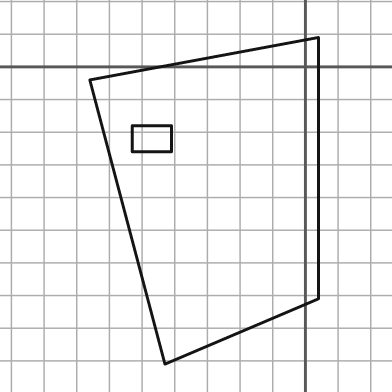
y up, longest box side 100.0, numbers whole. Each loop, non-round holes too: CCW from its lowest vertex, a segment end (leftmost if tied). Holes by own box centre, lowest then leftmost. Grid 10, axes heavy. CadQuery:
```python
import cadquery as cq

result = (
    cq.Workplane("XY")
    .moveTo(-43.0, -91.0)
    .lineTo(4.0, -71.0)
    .lineTo(4.0, 9.0)
    .lineTo(-66.0, -4.0)
    .close()
    .moveTo(-53.0, -26.0)
    .lineTo(-41.0, -26.0)
    .lineTo(-41.0, -18.0)
    .lineTo(-53.0, -18.0)
    .close()
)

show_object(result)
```